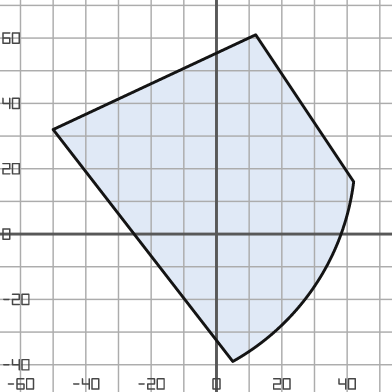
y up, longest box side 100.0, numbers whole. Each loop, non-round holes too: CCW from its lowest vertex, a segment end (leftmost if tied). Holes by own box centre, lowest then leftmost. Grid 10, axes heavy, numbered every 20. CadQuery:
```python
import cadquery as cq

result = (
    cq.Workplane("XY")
    .moveTo(5.0, -39.0)
    .threePointArc((30.0, -16.0), (42.0, 16.0))
    .lineTo(12.0, 61.0)
    .lineTo(-50.0, 32.0)
    .close()
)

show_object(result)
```